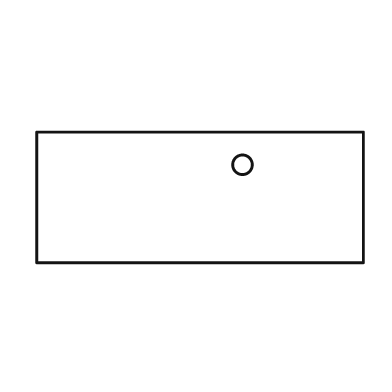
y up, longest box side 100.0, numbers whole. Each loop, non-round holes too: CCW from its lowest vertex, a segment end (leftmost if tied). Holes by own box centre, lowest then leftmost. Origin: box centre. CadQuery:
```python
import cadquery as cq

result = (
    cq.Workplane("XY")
    .moveTo(-50.0, -20.0)
    .lineTo(50.0, -20.0)
    .lineTo(50.0, 20.0)
    .lineTo(-50.0, 20.0)
    .close()
    .moveTo(13.0, 10.0)
    .circle(3.0)
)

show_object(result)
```